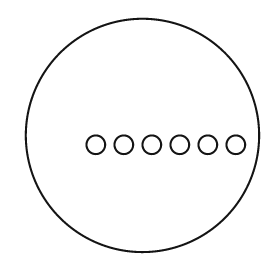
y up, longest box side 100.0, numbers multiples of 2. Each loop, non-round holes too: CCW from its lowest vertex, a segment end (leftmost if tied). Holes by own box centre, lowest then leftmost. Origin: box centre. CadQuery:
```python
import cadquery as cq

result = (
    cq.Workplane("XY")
    .moveTo(0.0, 0.0)
    .circle(50.0)
    .moveTo(-20.0, -4.0)
    .circle(4.0)
    .moveTo(-8.0, -4.0)
    .circle(4.0)
    .moveTo(4.0, -4.0)
    .circle(4.0)
    .moveTo(16.0, -4.0)
    .circle(4.0)
    .moveTo(28.0, -4.0)
    .circle(4.0)
    .moveTo(40.0, -4.0)
    .circle(4.0)
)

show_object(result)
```